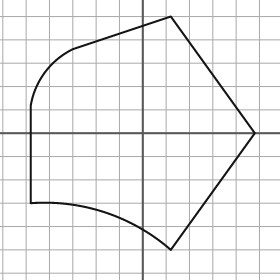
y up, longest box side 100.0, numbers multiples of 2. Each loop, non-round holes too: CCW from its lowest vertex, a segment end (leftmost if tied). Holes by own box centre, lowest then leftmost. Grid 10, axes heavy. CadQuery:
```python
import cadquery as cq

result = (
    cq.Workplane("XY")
    .moveTo(12.0, -50.0)
    .lineTo(48.0, 0.0)
    .lineTo(12.0, 50.0)
    .lineTo(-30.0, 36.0)
    .threePointArc((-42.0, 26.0), (-48.0, 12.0))
    .lineTo(-48.0, -30.0)
    .threePointArc((-16.0, -34.0), (12.0, -50.0))
    .close()
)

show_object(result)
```